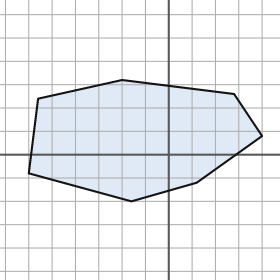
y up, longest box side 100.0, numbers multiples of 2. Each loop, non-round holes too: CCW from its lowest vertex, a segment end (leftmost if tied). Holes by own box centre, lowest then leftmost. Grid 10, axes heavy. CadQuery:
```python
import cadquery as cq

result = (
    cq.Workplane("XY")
    .moveTo(-16.0, -20.0)
    .lineTo(12.0, -12.0)
    .lineTo(40.0, 8.0)
    .lineTo(28.0, 26.0)
    .lineTo(-20.0, 32.0)
    .lineTo(-56.0, 24.0)
    .lineTo(-60.0, -8.0)
    .close()
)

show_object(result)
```